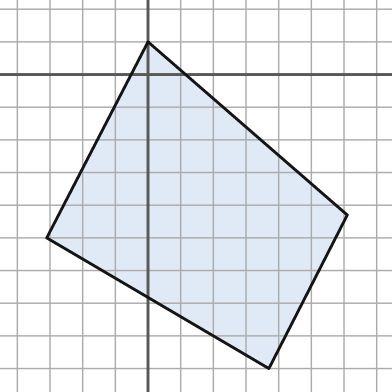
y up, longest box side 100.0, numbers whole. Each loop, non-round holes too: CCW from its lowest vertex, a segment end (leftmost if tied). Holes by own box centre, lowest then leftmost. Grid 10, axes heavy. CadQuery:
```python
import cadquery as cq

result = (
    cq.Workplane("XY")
    .moveTo(37.0, -90.0)
    .lineTo(61.0, -43.0)
    .lineTo(0.0, 10.0)
    .lineTo(-31.0, -50.0)
    .close()
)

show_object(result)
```